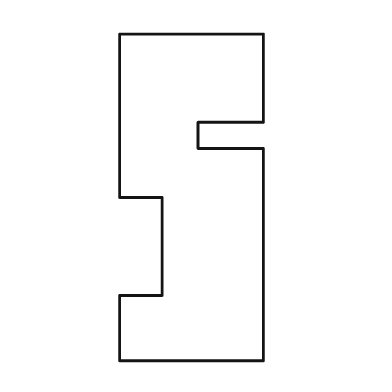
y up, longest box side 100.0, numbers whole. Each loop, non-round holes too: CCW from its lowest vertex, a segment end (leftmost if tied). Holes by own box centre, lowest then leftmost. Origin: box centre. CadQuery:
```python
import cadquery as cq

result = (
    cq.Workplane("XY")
    .moveTo(-22.0, -50.0)
    .lineTo(22.0, -50.0)
    .lineTo(22.0, 15.0)
    .lineTo(2.0, 15.0)
    .lineTo(2.0, 23.0)
    .lineTo(22.0, 23.0)
    .lineTo(22.0, 50.0)
    .lineTo(-22.0, 50.0)
    .lineTo(-22.0, 0.0)
    .lineTo(-9.0, 0.0)
    .lineTo(-9.0, -30.0)
    .lineTo(-22.0, -30.0)
    .close()
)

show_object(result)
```